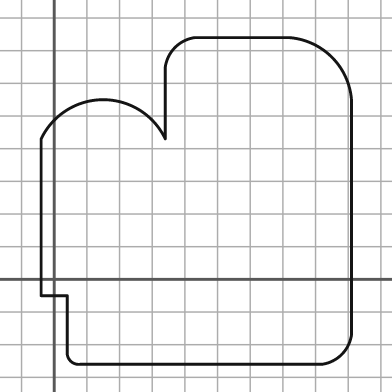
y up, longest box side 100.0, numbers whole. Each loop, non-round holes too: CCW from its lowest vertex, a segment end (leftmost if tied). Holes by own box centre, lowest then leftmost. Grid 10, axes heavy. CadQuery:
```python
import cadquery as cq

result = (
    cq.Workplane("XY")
    .moveTo(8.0, -26.0)
    .lineTo(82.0, -26.0)
    .threePointArc((88.0, -23.0), (91.0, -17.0))
    .lineTo(91.0, 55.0)
    .threePointArc((85.0, 68.0), (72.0, 74.0))
    .lineTo(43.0, 74.0)
    .threePointArc((37.0, 71.0), (34.0, 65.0))
    .lineTo(34.0, 43.0)
    .threePointArc((15.0, 55.0), (-4.0, 43.0))
    .lineTo(-4.0, -5.0)
    .lineTo(4.0, -5.0)
    .lineTo(4.0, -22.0)
    .threePointArc((5.0, -25.0), (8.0, -26.0))
    .close()
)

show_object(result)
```